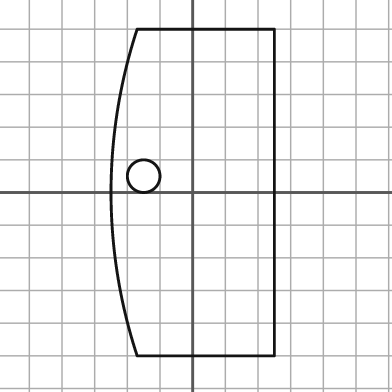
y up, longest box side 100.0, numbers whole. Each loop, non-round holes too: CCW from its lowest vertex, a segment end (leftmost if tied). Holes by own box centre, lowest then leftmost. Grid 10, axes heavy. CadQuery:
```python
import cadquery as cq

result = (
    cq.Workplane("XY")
    .moveTo(-17.0, -50.0)
    .lineTo(25.0, -50.0)
    .lineTo(25.0, 50.0)
    .lineTo(-17.0, 50.0)
    .threePointArc((-25.0, 0.0), (-17.0, -50.0))
    .close()
    .moveTo(-15.0, 5.0)
    .circle(5.0)
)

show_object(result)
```